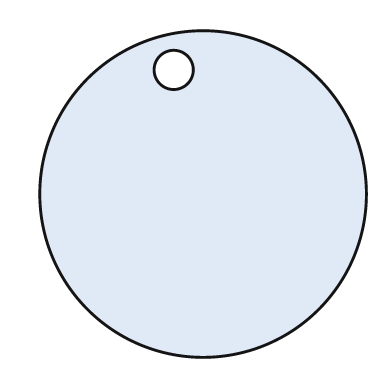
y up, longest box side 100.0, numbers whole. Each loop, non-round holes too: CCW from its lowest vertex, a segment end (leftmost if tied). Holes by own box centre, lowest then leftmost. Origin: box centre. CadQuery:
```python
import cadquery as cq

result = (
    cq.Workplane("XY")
    .moveTo(0.0, 0.0)
    .circle(50.0)
    .moveTo(-9.0, 38.0)
    .circle(6.0)
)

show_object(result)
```